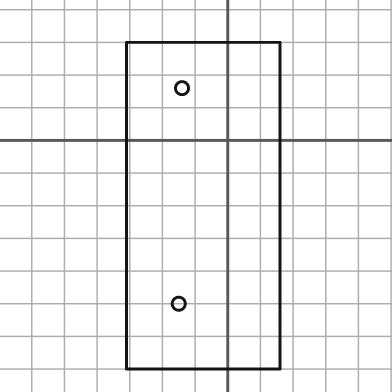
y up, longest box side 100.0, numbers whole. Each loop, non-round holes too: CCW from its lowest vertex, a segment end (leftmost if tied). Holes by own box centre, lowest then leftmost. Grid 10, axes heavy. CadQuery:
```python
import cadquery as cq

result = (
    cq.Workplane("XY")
    .moveTo(-31.0, -70.0)
    .lineTo(16.0, -70.0)
    .lineTo(16.0, 30.0)
    .lineTo(-31.0, 30.0)
    .close()
    .moveTo(-15.0, -50.0)
    .circle(2.0)
    .moveTo(-14.0, 16.0)
    .circle(2.0)
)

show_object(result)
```